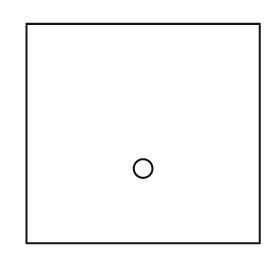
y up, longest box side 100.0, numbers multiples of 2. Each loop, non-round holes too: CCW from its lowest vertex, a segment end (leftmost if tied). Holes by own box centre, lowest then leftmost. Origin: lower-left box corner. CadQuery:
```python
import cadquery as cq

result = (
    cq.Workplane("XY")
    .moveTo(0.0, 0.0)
    .lineTo(100.0, 0.0)
    .lineTo(100.0, 94.0)
    .lineTo(0.0, 94.0)
    .close()
    .moveTo(50.0, 32.0)
    .circle(4.0)
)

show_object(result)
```